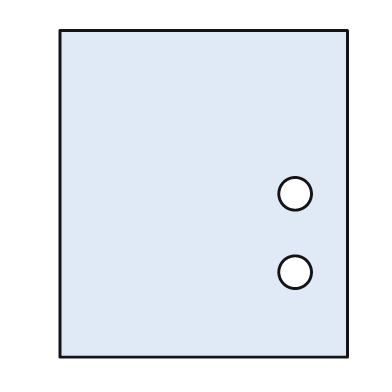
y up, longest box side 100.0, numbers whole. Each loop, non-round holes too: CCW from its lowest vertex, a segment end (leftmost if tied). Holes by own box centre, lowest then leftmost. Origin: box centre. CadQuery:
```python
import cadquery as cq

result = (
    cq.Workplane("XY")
    .moveTo(-44.0, -50.0)
    .lineTo(44.0, -50.0)
    .lineTo(44.0, 50.0)
    .lineTo(-44.0, 50.0)
    .close()
    .moveTo(28.0, -24.0)
    .circle(5.0)
    .moveTo(28.0, 0.0)
    .circle(5.0)
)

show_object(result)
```